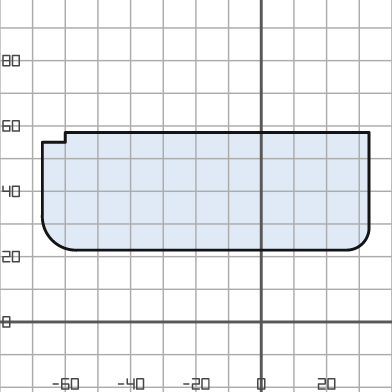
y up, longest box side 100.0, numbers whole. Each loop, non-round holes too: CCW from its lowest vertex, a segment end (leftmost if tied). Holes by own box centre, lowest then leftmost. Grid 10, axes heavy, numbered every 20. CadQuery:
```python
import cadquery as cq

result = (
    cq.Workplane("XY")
    .moveTo(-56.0, 22.0)
    .lineTo(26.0, 22.0)
    .threePointArc((31.0, 24.0), (33.0, 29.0))
    .lineTo(33.0, 58.0)
    .lineTo(-60.0, 58.0)
    .lineTo(-60.0, 55.0)
    .lineTo(-67.0, 55.0)
    .lineTo(-67.0, 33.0)
    .threePointArc((-64.0, 25.0), (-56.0, 22.0))
    .close()
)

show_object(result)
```